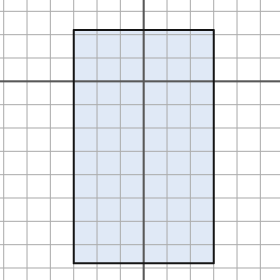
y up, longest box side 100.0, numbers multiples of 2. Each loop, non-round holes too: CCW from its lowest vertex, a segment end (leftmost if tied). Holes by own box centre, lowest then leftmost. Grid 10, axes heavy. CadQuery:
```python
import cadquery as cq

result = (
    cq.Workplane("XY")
    .moveTo(-30.0, -78.0)
    .lineTo(30.0, -78.0)
    .lineTo(30.0, 22.0)
    .lineTo(-30.0, 22.0)
    .close()
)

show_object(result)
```